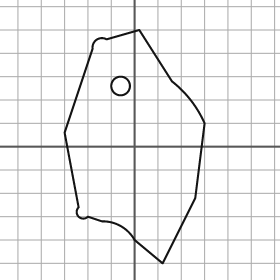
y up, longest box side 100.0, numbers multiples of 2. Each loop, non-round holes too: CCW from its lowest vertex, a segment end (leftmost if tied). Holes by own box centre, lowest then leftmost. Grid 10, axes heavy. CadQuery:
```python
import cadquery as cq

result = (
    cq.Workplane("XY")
    .moveTo(12.0, -50.0)
    .lineTo(26.0, -22.0)
    .lineTo(30.0, 10.0)
    .threePointArc((24.0, 20.0), (16.0, 28.0))
    .lineTo(2.0, 50.0)
    .lineTo(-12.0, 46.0)
    .threePointArc((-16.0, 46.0), (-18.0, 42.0))
    .lineTo(-30.0, 6.0)
    .lineTo(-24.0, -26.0)
    .threePointArc((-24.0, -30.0), (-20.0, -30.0))
    .lineTo(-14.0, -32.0)
    .threePointArc((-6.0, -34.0), (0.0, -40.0))
    .close()
    .moveTo(-6.0, 26.0)
    .circle(4.0)
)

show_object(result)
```